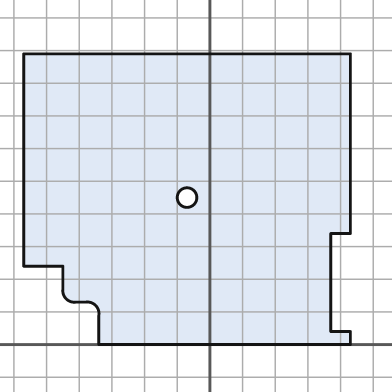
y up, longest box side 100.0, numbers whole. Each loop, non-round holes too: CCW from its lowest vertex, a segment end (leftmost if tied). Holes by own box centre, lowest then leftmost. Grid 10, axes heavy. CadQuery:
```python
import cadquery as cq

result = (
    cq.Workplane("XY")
    .moveTo(-34.0, 0.0)
    .lineTo(43.0, 0.0)
    .lineTo(43.0, 4.0)
    .lineTo(37.0, 4.0)
    .lineTo(37.0, 34.0)
    .lineTo(43.0, 34.0)
    .lineTo(43.0, 89.0)
    .lineTo(-57.0, 89.0)
    .lineTo(-57.0, 24.0)
    .lineTo(-45.0, 24.0)
    .lineTo(-45.0, 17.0)
    .threePointArc((-44.0, 14.0), (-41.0, 13.0))
    .lineTo(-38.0, 13.0)
    .threePointArc((-35.0, 12.0), (-34.0, 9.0))
    .close()
    .moveTo(-7.0, 45.0)
    .circle(3.0)
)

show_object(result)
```